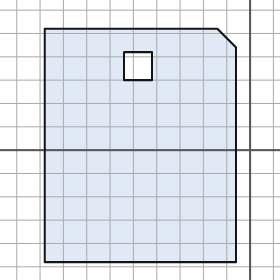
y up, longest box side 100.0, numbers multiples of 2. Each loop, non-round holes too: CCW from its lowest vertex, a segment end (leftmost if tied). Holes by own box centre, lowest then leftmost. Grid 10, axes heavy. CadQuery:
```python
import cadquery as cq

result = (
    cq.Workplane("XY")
    .moveTo(-88.0, -48.0)
    .lineTo(-6.0, -48.0)
    .lineTo(-6.0, 44.0)
    .lineTo(-14.0, 52.0)
    .lineTo(-88.0, 52.0)
    .close()
    .moveTo(-54.0, 30.0)
    .lineTo(-42.0, 30.0)
    .lineTo(-42.0, 42.0)
    .lineTo(-54.0, 42.0)
    .close()
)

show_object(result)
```